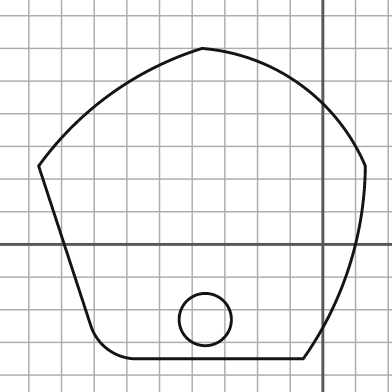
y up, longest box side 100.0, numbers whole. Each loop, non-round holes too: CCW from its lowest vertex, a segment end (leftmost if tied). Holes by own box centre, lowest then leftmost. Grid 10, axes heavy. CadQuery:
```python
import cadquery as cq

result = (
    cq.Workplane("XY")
    .moveTo(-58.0, -35.0)
    .lineTo(-6.0, -35.0)
    .threePointArc((8.0, -7.0), (13.0, 24.0))
    .threePointArc((-7.0, 49.0), (-37.0, 60.0))
    .threePointArc((-65.0, 46.0), (-87.0, 24.0))
    .lineTo(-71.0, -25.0)
    .threePointArc((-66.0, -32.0), (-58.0, -35.0))
    .close()
    .moveTo(-36.0, -23.0)
    .circle(8.0)
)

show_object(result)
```